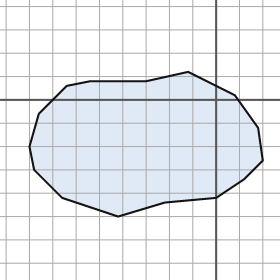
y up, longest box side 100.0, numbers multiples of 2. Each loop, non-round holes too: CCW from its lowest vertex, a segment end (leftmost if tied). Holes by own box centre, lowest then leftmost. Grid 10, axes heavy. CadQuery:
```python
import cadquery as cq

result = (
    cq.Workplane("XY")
    .moveTo(-42.0, -50.0)
    .lineTo(-22.0, -44.0)
    .lineTo(0.0, -42.0)
    .lineTo(12.0, -34.0)
    .lineTo(20.0, -26.0)
    .lineTo(18.0, -12.0)
    .lineTo(8.0, 2.0)
    .lineTo(-12.0, 12.0)
    .lineTo(-30.0, 8.0)
    .lineTo(-54.0, 8.0)
    .lineTo(-64.0, 6.0)
    .lineTo(-76.0, -6.0)
    .lineTo(-80.0, -20.0)
    .lineTo(-78.0, -30.0)
    .lineTo(-66.0, -42.0)
    .close()
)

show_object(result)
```